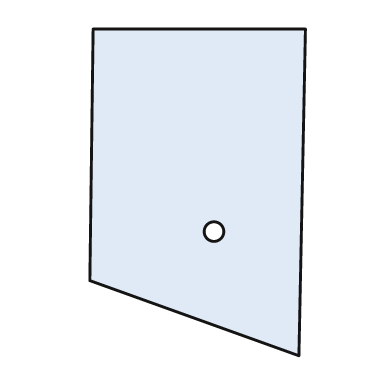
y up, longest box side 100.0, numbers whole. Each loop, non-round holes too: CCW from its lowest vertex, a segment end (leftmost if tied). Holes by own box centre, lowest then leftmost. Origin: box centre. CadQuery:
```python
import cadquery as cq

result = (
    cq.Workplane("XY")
    .moveTo(31.0, -50.0)
    .lineTo(33.0, 50.0)
    .lineTo(-32.0, 50.0)
    .lineTo(-33.0, -27.0)
    .close()
    .moveTo(5.0, -12.0)
    .circle(3.0)
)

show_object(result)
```